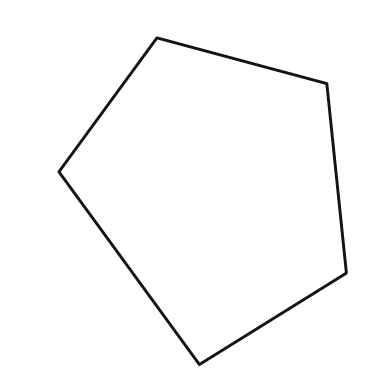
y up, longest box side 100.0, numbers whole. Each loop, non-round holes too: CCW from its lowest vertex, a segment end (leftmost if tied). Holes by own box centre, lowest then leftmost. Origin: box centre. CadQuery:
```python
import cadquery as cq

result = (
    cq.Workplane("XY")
    .moveTo(-1.0, -50.0)
    .lineTo(44.0, -22.0)
    .lineTo(38.0, 36.0)
    .lineTo(-14.0, 50.0)
    .lineTo(-44.0, 9.0)
    .close()
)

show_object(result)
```